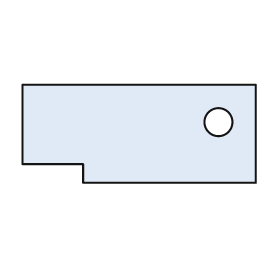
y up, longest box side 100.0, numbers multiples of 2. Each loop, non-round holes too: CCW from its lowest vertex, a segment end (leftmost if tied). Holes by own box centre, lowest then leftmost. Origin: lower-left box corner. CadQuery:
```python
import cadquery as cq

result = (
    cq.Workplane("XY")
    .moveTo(26.0, 0.0)
    .lineTo(100.0, 0.0)
    .lineTo(100.0, 42.0)
    .lineTo(0.0, 42.0)
    .lineTo(0.0, 8.0)
    .lineTo(26.0, 8.0)
    .close()
    .moveTo(84.0, 26.0)
    .circle(6.0)
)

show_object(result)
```